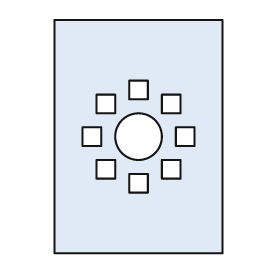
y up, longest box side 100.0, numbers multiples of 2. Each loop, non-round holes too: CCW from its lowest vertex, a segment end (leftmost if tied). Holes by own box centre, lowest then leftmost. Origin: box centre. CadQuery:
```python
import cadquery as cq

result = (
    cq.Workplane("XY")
    .moveTo(-36.0, -50.0)
    .lineTo(36.0, -50.0)
    .lineTo(36.0, 50.0)
    .lineTo(-36.0, 50.0)
    .close()
    .moveTo(-4.0, -24.0)
    .lineTo(4.0, -24.0)
    .lineTo(4.0, -16.0)
    .lineTo(-4.0, -16.0)
    .close()
    .moveTo(-18.0, -18.0)
    .lineTo(-10.0, -18.0)
    .lineTo(-10.0, -10.0)
    .lineTo(-18.0, -10.0)
    .close()
    .moveTo(10.0, -18.0)
    .lineTo(18.0, -18.0)
    .lineTo(18.0, -10.0)
    .lineTo(10.0, -10.0)
    .close()
    .moveTo(-24.0, -4.0)
    .lineTo(-16.0, -4.0)
    .lineTo(-16.0, 4.0)
    .lineTo(-24.0, 4.0)
    .close()
    .moveTo(0.0, 0.0)
    .circle(10.0)
    .moveTo(16.0, -4.0)
    .lineTo(24.0, -4.0)
    .lineTo(24.0, 4.0)
    .lineTo(16.0, 4.0)
    .close()
    .moveTo(-18.0, 10.0)
    .lineTo(-10.0, 10.0)
    .lineTo(-10.0, 18.0)
    .lineTo(-18.0, 18.0)
    .close()
    .moveTo(10.0, 10.0)
    .lineTo(18.0, 10.0)
    .lineTo(18.0, 18.0)
    .lineTo(10.0, 18.0)
    .close()
    .moveTo(-4.0, 16.0)
    .lineTo(4.0, 16.0)
    .lineTo(4.0, 24.0)
    .lineTo(-4.0, 24.0)
    .close()
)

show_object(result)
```